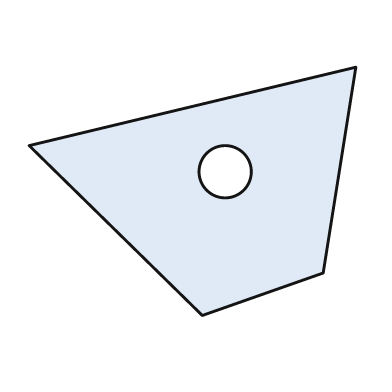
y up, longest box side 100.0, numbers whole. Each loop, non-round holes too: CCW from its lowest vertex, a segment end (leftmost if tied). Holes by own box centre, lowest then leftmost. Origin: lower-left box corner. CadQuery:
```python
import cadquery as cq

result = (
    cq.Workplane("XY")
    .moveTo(53.0, 0.0)
    .lineTo(90.0, 13.0)
    .lineTo(100.0, 76.0)
    .lineTo(0.0, 52.0)
    .close()
    .moveTo(60.0, 44.0)
    .circle(8.0)
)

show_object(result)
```